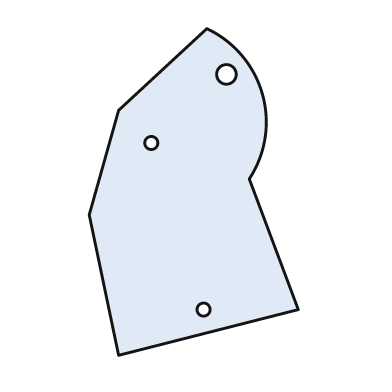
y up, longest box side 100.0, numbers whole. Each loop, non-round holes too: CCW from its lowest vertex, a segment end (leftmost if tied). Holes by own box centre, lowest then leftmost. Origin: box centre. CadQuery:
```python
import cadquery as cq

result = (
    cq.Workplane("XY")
    .moveTo(-23.0, -50.0)
    .lineTo(32.0, -36.0)
    .lineTo(17.0, 4.0)
    .threePointArc((21.0, 30.0), (4.0, 50.0))
    .lineTo(-23.0, 25.0)
    .lineTo(-32.0, -7.0)
    .close()
    .moveTo(3.0, -36.0)
    .circle(2.0)
    .moveTo(-13.0, 15.0)
    .circle(2.0)
    .moveTo(10.0, 36.0)
    .circle(3.0)
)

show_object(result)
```